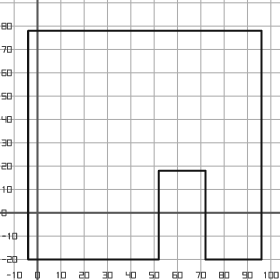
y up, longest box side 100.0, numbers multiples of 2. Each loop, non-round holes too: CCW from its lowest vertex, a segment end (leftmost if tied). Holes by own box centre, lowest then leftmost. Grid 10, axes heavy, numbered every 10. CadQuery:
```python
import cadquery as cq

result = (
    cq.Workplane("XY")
    .moveTo(-4.0, -20.0)
    .lineTo(52.0, -20.0)
    .lineTo(52.0, 18.0)
    .lineTo(72.0, 18.0)
    .lineTo(72.0, -20.0)
    .lineTo(96.0, -20.0)
    .lineTo(96.0, 78.0)
    .lineTo(-4.0, 78.0)
    .close()
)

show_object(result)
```